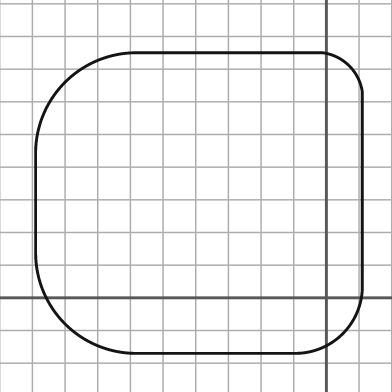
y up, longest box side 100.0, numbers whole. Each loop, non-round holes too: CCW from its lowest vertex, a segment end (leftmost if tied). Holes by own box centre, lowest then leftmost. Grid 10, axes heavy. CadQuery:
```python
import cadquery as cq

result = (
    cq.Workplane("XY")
    .moveTo(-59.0, -17.0)
    .lineTo(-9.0, -17.0)
    .threePointArc((5.0, -11.0), (11.0, 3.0))
    .lineTo(11.0, 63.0)
    .threePointArc((7.0, 71.0), (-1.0, 75.0))
    .lineTo(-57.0, 75.0)
    .threePointArc((-80.0, 66.0), (-89.0, 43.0))
    .lineTo(-89.0, 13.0)
    .threePointArc((-80.0, -8.0), (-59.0, -17.0))
    .close()
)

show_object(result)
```